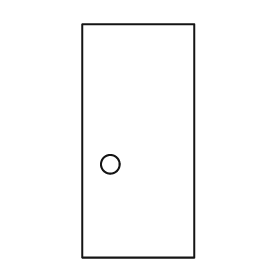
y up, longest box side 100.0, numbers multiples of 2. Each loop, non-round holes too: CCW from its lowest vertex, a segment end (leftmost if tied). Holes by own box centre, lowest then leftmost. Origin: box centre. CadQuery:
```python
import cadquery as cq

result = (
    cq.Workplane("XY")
    .moveTo(-24.0, -50.0)
    .lineTo(24.0, -50.0)
    .lineTo(24.0, 50.0)
    .lineTo(-24.0, 50.0)
    .close()
    .moveTo(-12.0, -10.0)
    .circle(4.0)
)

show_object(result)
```